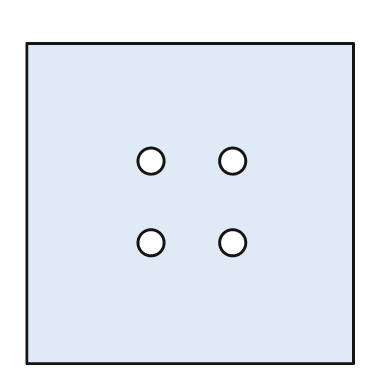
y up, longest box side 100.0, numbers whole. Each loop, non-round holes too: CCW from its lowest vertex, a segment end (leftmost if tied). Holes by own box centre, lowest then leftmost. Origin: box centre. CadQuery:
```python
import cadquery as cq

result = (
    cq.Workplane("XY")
    .moveTo(-50.0, -49.0)
    .lineTo(50.0, -49.0)
    .lineTo(50.0, 49.0)
    .lineTo(-50.0, 49.0)
    .close()
    .moveTo(-12.0, -12.0)
    .circle(4.0)
    .moveTo(13.0, -12.0)
    .circle(4.0)
    .moveTo(-12.0, 13.0)
    .circle(4.0)
    .moveTo(13.0, 13.0)
    .circle(4.0)
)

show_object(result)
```